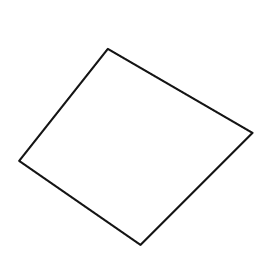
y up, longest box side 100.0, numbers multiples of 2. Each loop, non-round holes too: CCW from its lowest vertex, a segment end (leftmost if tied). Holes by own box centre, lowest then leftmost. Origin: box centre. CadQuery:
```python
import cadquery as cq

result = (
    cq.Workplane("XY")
    .moveTo(2.0, -42.0)
    .lineTo(50.0, 6.0)
    .lineTo(-12.0, 42.0)
    .lineTo(-50.0, -6.0)
    .close()
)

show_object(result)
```